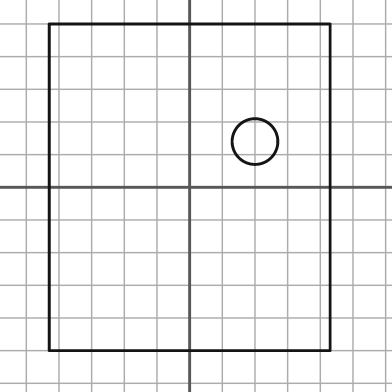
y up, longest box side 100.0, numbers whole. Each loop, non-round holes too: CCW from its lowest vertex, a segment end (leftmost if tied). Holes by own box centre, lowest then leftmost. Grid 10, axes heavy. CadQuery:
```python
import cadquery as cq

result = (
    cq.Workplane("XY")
    .moveTo(-43.0, -50.0)
    .lineTo(43.0, -50.0)
    .lineTo(43.0, 50.0)
    .lineTo(-43.0, 50.0)
    .close()
    .moveTo(20.0, 14.0)
    .circle(7.0)
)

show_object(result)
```